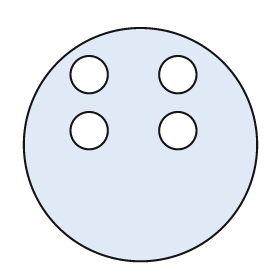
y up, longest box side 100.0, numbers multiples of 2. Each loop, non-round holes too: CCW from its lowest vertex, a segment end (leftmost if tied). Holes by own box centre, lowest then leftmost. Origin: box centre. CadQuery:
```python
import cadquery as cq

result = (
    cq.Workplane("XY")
    .moveTo(0.0, 0.0)
    .circle(50.0)
    .moveTo(-22.0, 6.0)
    .circle(8.0)
    .moveTo(16.0, 6.0)
    .circle(8.0)
    .moveTo(-22.0, 30.0)
    .circle(8.0)
    .moveTo(16.0, 30.0)
    .circle(8.0)
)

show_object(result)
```